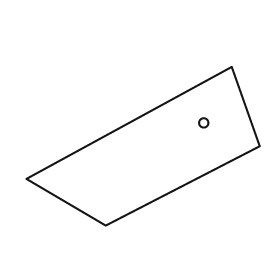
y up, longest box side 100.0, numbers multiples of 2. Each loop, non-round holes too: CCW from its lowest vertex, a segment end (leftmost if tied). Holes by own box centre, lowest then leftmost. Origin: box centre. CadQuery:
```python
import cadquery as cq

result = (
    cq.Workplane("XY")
    .moveTo(-16.0, -34.0)
    .lineTo(50.0, 0.0)
    .lineTo(38.0, 34.0)
    .lineTo(-50.0, -14.0)
    .close()
    .moveTo(26.0, 10.0)
    .circle(2.0)
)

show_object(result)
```